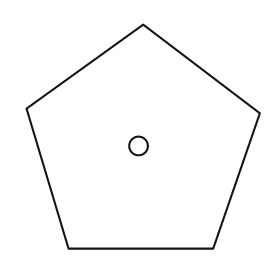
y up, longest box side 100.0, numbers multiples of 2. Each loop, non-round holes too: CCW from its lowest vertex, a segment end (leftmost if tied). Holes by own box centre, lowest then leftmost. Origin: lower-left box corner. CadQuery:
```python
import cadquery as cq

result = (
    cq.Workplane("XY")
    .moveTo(18.0, 0.0)
    .lineTo(80.0, 0.0)
    .lineTo(100.0, 58.0)
    .lineTo(50.0, 96.0)
    .lineTo(0.0, 60.0)
    .close()
    .moveTo(48.0, 44.0)
    .circle(4.0)
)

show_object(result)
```